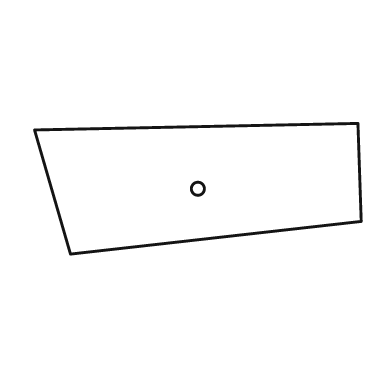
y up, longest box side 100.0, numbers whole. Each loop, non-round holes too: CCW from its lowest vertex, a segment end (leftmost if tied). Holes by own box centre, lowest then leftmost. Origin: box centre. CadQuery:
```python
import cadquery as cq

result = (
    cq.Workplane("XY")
    .moveTo(-39.0, -20.0)
    .lineTo(50.0, -10.0)
    .lineTo(49.0, 20.0)
    .lineTo(-50.0, 18.0)
    .close()
    .moveTo(0.0, 0.0)
    .circle(2.0)
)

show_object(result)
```